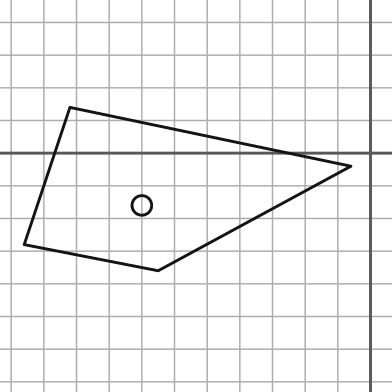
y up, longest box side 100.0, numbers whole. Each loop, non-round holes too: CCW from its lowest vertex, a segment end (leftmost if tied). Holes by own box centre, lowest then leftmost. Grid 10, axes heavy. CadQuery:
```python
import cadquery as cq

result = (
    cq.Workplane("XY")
    .moveTo(-65.0, -36.0)
    .lineTo(-6.0, -4.0)
    .lineTo(-92.0, 14.0)
    .lineTo(-106.0, -28.0)
    .close()
    .moveTo(-70.0, -16.0)
    .circle(3.0)
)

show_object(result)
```